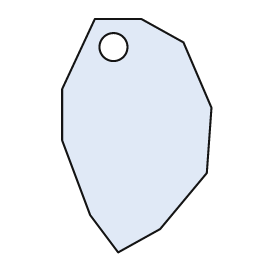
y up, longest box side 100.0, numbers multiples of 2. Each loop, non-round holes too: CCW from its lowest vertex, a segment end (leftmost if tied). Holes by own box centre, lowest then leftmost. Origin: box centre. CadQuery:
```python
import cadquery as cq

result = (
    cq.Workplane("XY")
    .moveTo(-8.0, -50.0)
    .lineTo(10.0, -40.0)
    .lineTo(30.0, -16.0)
    .lineTo(32.0, 12.0)
    .lineTo(20.0, 40.0)
    .lineTo(2.0, 50.0)
    .lineTo(-18.0, 50.0)
    .lineTo(-32.0, 20.0)
    .lineTo(-32.0, -2.0)
    .lineTo(-20.0, -34.0)
    .close()
    .moveTo(-10.0, 38.0)
    .circle(6.0)
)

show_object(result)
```